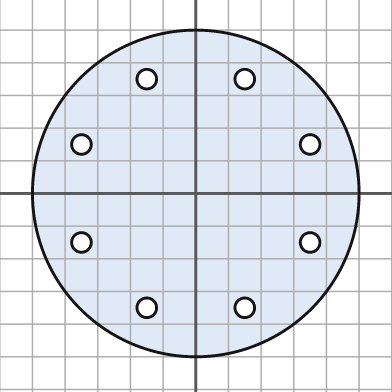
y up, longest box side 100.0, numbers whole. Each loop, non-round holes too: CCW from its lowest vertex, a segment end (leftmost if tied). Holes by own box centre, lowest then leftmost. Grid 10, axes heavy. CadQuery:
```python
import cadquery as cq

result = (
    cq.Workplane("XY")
    .moveTo(0.0, 0.0)
    .circle(50.0)
    .moveTo(-15.0, -35.0)
    .circle(3.0)
    .moveTo(15.0, -35.0)
    .circle(3.0)
    .moveTo(-35.0, -15.0)
    .circle(3.0)
    .moveTo(35.0, -15.0)
    .circle(3.0)
    .moveTo(-35.0, 15.0)
    .circle(3.0)
    .moveTo(35.0, 15.0)
    .circle(3.0)
    .moveTo(-15.0, 35.0)
    .circle(3.0)
    .moveTo(15.0, 35.0)
    .circle(3.0)
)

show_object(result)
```